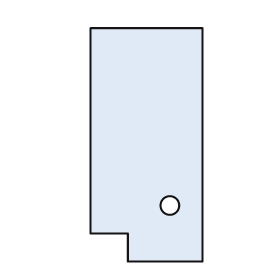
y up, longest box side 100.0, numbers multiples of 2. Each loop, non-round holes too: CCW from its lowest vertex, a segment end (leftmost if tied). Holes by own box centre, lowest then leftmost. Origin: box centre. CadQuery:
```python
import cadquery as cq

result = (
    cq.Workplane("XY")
    .moveTo(-8.0, -50.0)
    .lineTo(24.0, -50.0)
    .lineTo(24.0, 50.0)
    .lineTo(-24.0, 50.0)
    .lineTo(-24.0, -38.0)
    .lineTo(-8.0, -38.0)
    .close()
    .moveTo(10.0, -26.0)
    .circle(4.0)
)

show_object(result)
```